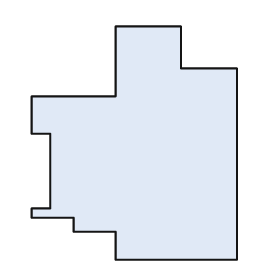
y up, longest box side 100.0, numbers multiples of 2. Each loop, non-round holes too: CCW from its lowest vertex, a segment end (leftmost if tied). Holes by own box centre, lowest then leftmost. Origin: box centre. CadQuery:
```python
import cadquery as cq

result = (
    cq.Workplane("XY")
    .moveTo(-8.0, -50.0)
    .lineTo(44.0, -50.0)
    .lineTo(44.0, 32.0)
    .lineTo(20.0, 32.0)
    .lineTo(20.0, 50.0)
    .lineTo(-8.0, 50.0)
    .lineTo(-8.0, 20.0)
    .lineTo(-44.0, 20.0)
    .lineTo(-44.0, 4.0)
    .lineTo(-36.0, 4.0)
    .lineTo(-36.0, -28.0)
    .lineTo(-44.0, -28.0)
    .lineTo(-44.0, -32.0)
    .lineTo(-26.0, -32.0)
    .lineTo(-26.0, -38.0)
    .lineTo(-8.0, -38.0)
    .close()
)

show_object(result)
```